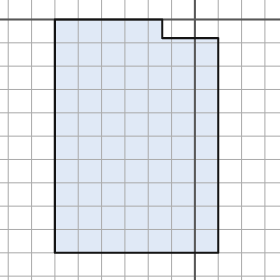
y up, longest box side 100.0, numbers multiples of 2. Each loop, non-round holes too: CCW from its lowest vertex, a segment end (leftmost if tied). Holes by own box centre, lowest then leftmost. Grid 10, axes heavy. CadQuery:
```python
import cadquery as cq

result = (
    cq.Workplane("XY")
    .moveTo(-60.0, -100.0)
    .lineTo(10.0, -100.0)
    .lineTo(10.0, -8.0)
    .lineTo(-14.0, -8.0)
    .lineTo(-14.0, 0.0)
    .lineTo(-60.0, 0.0)
    .close()
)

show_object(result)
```